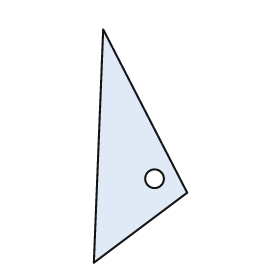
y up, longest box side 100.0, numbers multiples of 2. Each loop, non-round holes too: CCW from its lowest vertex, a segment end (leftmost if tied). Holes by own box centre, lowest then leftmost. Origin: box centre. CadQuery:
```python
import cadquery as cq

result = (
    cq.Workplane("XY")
    .moveTo(-20.0, -50.0)
    .lineTo(20.0, -20.0)
    .lineTo(-16.0, 50.0)
    .close()
    .moveTo(6.0, -14.0)
    .circle(4.0)
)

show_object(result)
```